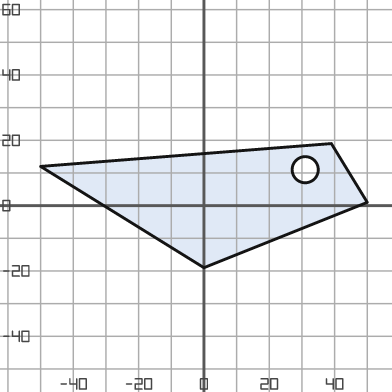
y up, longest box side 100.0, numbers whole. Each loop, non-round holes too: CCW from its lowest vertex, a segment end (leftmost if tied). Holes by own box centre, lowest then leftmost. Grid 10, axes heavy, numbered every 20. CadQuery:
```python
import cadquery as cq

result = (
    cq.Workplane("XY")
    .moveTo(0.0, -19.0)
    .lineTo(50.0, 1.0)
    .lineTo(39.0, 19.0)
    .lineTo(-50.0, 12.0)
    .close()
    .moveTo(31.0, 11.0)
    .circle(4.0)
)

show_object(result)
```